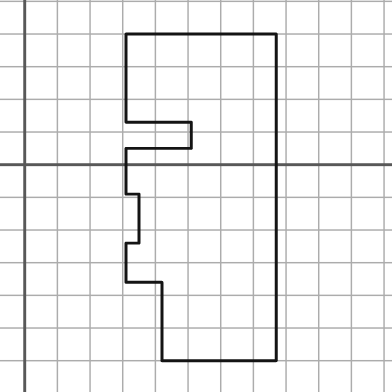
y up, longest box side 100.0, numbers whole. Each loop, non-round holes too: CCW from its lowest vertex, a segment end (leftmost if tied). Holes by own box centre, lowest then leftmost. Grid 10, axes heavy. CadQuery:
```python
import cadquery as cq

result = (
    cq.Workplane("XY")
    .moveTo(42.0, -60.0)
    .lineTo(77.0, -60.0)
    .lineTo(77.0, 40.0)
    .lineTo(31.0, 40.0)
    .lineTo(31.0, 13.0)
    .lineTo(51.0, 13.0)
    .lineTo(51.0, 5.0)
    .lineTo(31.0, 5.0)
    .lineTo(31.0, -9.0)
    .lineTo(35.0, -9.0)
    .lineTo(35.0, -24.0)
    .lineTo(31.0, -24.0)
    .lineTo(31.0, -36.0)
    .lineTo(42.0, -36.0)
    .close()
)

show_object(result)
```